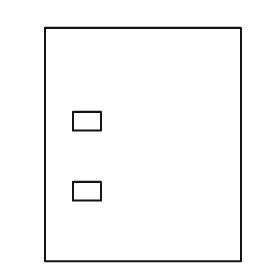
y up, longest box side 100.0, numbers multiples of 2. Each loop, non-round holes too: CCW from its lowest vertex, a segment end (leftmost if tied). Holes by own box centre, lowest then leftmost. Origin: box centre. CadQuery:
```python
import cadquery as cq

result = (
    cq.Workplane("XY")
    .moveTo(-42.0, -50.0)
    .lineTo(42.0, -50.0)
    .lineTo(42.0, 50.0)
    .lineTo(-42.0, 50.0)
    .close()
    .moveTo(-30.0, -24.0)
    .lineTo(-18.0, -24.0)
    .lineTo(-18.0, -16.0)
    .lineTo(-30.0, -16.0)
    .close()
    .moveTo(-30.0, 6.0)
    .lineTo(-18.0, 6.0)
    .lineTo(-18.0, 14.0)
    .lineTo(-30.0, 14.0)
    .close()
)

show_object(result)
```